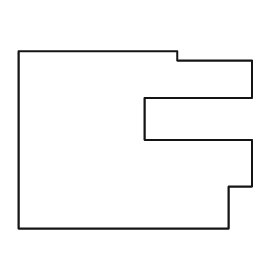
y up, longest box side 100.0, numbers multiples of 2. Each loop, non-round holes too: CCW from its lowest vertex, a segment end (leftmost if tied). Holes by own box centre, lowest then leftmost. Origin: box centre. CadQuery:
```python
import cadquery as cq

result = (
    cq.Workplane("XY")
    .moveTo(-50.0, -38.0)
    .lineTo(40.0, -38.0)
    .lineTo(40.0, -20.0)
    .lineTo(50.0, -20.0)
    .lineTo(50.0, 0.0)
    .lineTo(4.0, 0.0)
    .lineTo(4.0, 18.0)
    .lineTo(50.0, 18.0)
    .lineTo(50.0, 34.0)
    .lineTo(18.0, 34.0)
    .lineTo(18.0, 38.0)
    .lineTo(-50.0, 38.0)
    .close()
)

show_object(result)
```